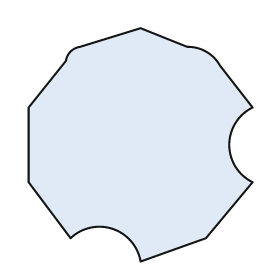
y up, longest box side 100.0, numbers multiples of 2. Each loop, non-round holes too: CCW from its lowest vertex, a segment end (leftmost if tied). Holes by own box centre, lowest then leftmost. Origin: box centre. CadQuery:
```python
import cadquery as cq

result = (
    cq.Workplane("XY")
    .moveTo(0.0, -50.0)
    .lineTo(28.0, -40.0)
    .lineTo(48.0, -16.0)
    .threePointArc((38.0, 0.0), (48.0, 16.0))
    .lineTo(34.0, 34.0)
    .threePointArc((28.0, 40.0), (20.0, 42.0))
    .lineTo(0.0, 50.0)
    .lineTo(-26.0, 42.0)
    .threePointArc((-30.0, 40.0), (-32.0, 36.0))
    .lineTo(-48.0, 16.0)
    .lineTo(-48.0, -16.0)
    .lineTo(-30.0, -40.0)
    .threePointArc((-12.0, -36.0), (0.0, -50.0))
    .close()
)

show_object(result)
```